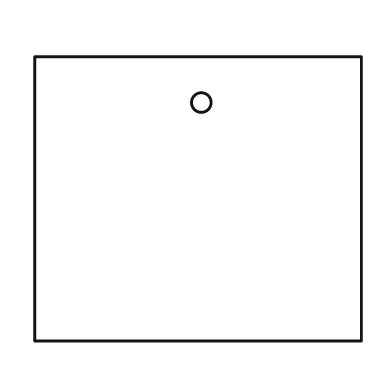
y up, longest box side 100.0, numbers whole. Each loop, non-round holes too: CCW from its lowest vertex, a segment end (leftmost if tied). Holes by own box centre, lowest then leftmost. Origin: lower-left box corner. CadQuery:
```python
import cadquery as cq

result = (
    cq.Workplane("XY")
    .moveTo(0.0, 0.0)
    .lineTo(100.0, 0.0)
    .lineTo(100.0, 87.0)
    .lineTo(0.0, 87.0)
    .close()
    .moveTo(51.0, 73.0)
    .circle(3.0)
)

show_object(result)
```